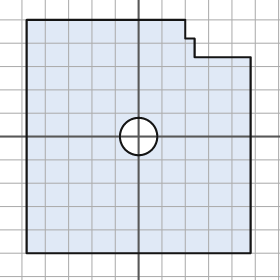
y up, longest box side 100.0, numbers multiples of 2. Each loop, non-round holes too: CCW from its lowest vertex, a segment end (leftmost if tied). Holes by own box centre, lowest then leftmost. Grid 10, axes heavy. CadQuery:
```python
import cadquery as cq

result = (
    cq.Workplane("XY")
    .moveTo(-48.0, -50.0)
    .lineTo(48.0, -50.0)
    .lineTo(48.0, 34.0)
    .lineTo(24.0, 34.0)
    .lineTo(24.0, 42.0)
    .lineTo(20.0, 42.0)
    .lineTo(20.0, 50.0)
    .lineTo(-48.0, 50.0)
    .close()
    .moveTo(0.0, 0.0)
    .circle(8.0)
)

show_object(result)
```